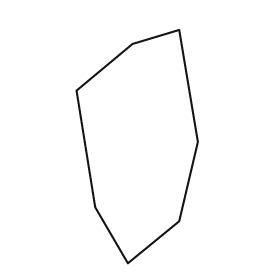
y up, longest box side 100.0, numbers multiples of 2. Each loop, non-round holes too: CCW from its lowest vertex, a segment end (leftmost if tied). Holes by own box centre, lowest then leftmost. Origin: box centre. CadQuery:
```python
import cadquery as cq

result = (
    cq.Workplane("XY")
    .moveTo(-4.0, -50.0)
    .lineTo(18.0, -32.0)
    .lineTo(26.0, 2.0)
    .lineTo(18.0, 50.0)
    .lineTo(-2.0, 44.0)
    .lineTo(-26.0, 24.0)
    .lineTo(-18.0, -26.0)
    .close()
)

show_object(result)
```